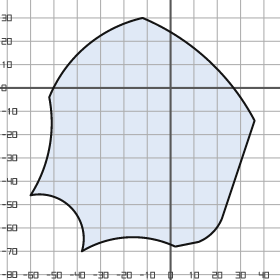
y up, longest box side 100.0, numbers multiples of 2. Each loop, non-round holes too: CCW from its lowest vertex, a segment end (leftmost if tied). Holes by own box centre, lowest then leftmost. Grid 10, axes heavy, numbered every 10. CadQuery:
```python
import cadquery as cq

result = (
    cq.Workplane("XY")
    .moveTo(-38.0, -70.0)
    .threePointArc((-18.0, -64.0), (2.0, -68.0))
    .lineTo(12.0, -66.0)
    .threePointArc((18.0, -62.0), (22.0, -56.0))
    .lineTo(36.0, -14.0)
    .threePointArc((16.0, 12.0), (-12.0, 30.0))
    .threePointArc((-36.0, 18.0), (-52.0, -4.0))
    .threePointArc((-52.0, -26.0), (-60.0, -46.0))
    .threePointArc((-42.0, -52.0), (-38.0, -70.0))
    .close()
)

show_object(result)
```